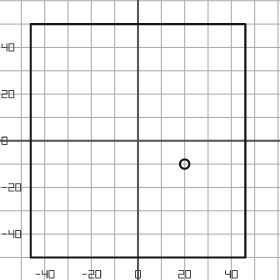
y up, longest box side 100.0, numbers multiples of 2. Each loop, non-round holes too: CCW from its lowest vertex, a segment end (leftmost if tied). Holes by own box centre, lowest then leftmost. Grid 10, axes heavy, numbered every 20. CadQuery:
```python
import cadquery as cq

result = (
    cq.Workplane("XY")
    .moveTo(-46.0, -50.0)
    .lineTo(46.0, -50.0)
    .lineTo(46.0, 50.0)
    .lineTo(-46.0, 50.0)
    .close()
    .moveTo(20.0, -10.0)
    .circle(2.0)
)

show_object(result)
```